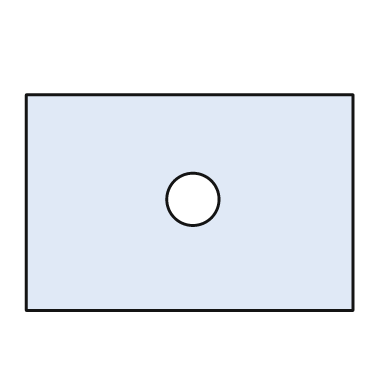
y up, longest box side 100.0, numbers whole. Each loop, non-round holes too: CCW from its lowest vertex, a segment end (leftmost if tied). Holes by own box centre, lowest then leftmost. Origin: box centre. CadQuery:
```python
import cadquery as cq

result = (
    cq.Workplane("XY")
    .moveTo(-50.0, -33.0)
    .lineTo(50.0, -33.0)
    .lineTo(50.0, 33.0)
    .lineTo(-50.0, 33.0)
    .close()
    .moveTo(1.0, 1.0)
    .circle(8.0)
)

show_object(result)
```